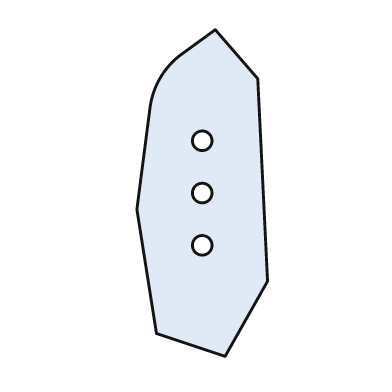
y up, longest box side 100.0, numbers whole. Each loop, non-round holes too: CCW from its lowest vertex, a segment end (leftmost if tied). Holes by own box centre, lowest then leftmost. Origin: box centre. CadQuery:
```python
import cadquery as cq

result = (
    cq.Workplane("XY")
    .moveTo(7.0, -50.0)
    .lineTo(20.0, -27.0)
    .lineTo(17.0, 35.0)
    .lineTo(4.0, 50.0)
    .lineTo(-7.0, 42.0)
    .threePointArc((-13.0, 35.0), (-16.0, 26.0))
    .lineTo(-20.0, -5.0)
    .lineTo(-14.0, -43.0)
    .close()
    .moveTo(0.0, -16.0)
    .circle(3.0)
    .moveTo(0.0, 0.0)
    .circle(3.0)
    .moveTo(0.0, 16.0)
    .circle(3.0)
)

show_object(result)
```